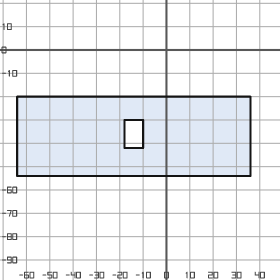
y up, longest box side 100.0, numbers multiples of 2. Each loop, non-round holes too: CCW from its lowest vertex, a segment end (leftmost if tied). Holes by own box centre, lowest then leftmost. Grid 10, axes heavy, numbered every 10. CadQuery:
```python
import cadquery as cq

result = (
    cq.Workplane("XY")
    .moveTo(-64.0, -54.0)
    .lineTo(36.0, -54.0)
    .lineTo(36.0, -20.0)
    .lineTo(-64.0, -20.0)
    .close()
    .moveTo(-18.0, -42.0)
    .lineTo(-10.0, -42.0)
    .lineTo(-10.0, -30.0)
    .lineTo(-18.0, -30.0)
    .close()
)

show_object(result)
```